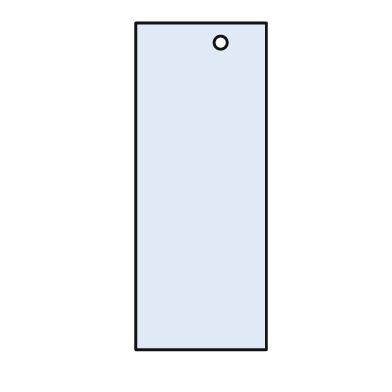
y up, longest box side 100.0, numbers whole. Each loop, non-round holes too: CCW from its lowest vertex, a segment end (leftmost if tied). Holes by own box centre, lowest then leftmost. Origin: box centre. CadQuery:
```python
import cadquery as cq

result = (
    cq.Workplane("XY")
    .moveTo(-20.0, -50.0)
    .lineTo(20.0, -50.0)
    .lineTo(20.0, 50.0)
    .lineTo(-20.0, 50.0)
    .close()
    .moveTo(6.0, 44.0)
    .circle(2.0)
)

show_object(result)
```